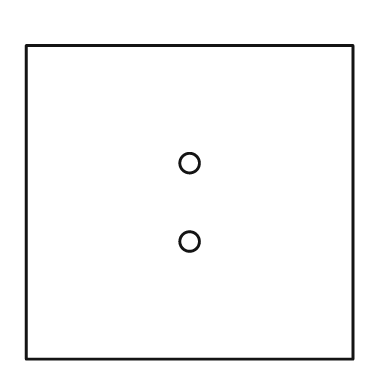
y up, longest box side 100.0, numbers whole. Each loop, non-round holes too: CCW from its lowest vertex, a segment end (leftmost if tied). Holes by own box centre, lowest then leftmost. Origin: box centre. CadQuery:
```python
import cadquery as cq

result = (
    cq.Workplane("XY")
    .moveTo(-50.0, -48.0)
    .lineTo(50.0, -48.0)
    .lineTo(50.0, 48.0)
    .lineTo(-50.0, 48.0)
    .close()
    .moveTo(0.0, -12.0)
    .circle(3.0)
    .moveTo(0.0, 12.0)
    .circle(3.0)
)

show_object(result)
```